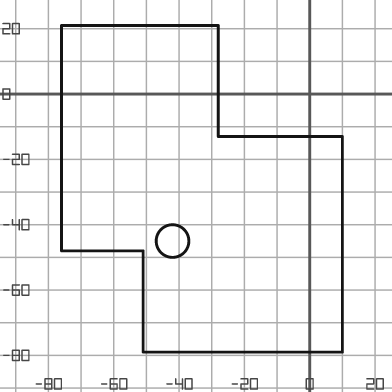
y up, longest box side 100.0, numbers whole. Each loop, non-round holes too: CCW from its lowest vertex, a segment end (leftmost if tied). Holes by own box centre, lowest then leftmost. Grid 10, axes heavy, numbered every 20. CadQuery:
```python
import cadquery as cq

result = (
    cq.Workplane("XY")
    .moveTo(-51.0, -79.0)
    .lineTo(10.0, -79.0)
    .lineTo(10.0, -13.0)
    .lineTo(-28.0, -13.0)
    .lineTo(-28.0, 21.0)
    .lineTo(-76.0, 21.0)
    .lineTo(-76.0, -48.0)
    .lineTo(-51.0, -48.0)
    .close()
    .moveTo(-42.0, -45.0)
    .circle(5.0)
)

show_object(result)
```